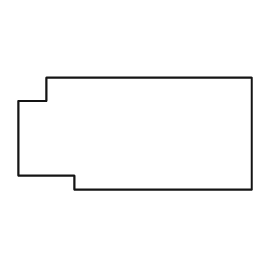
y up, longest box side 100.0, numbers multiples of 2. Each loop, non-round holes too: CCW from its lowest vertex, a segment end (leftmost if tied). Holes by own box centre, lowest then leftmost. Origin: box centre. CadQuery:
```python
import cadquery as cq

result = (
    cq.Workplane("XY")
    .moveTo(-26.0, -24.0)
    .lineTo(50.0, -24.0)
    .lineTo(50.0, 24.0)
    .lineTo(-38.0, 24.0)
    .lineTo(-38.0, 14.0)
    .lineTo(-50.0, 14.0)
    .lineTo(-50.0, -18.0)
    .lineTo(-26.0, -18.0)
    .close()
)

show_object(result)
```